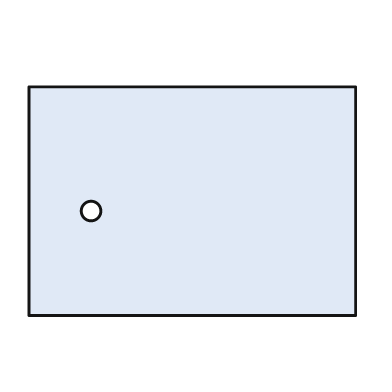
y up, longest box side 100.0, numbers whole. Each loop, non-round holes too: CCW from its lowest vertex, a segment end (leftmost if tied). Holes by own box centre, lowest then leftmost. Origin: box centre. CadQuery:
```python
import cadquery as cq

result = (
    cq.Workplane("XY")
    .moveTo(-50.0, -35.0)
    .lineTo(50.0, -35.0)
    .lineTo(50.0, 35.0)
    .lineTo(-50.0, 35.0)
    .close()
    .moveTo(-31.0, -3.0)
    .circle(3.0)
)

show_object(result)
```